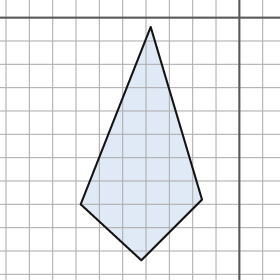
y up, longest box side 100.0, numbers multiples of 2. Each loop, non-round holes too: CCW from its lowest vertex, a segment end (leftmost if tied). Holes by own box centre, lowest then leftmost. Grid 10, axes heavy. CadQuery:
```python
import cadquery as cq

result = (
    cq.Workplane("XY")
    .moveTo(-42.0, -104.0)
    .lineTo(-16.0, -78.0)
    .lineTo(-38.0, -4.0)
    .lineTo(-68.0, -80.0)
    .close()
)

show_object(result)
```